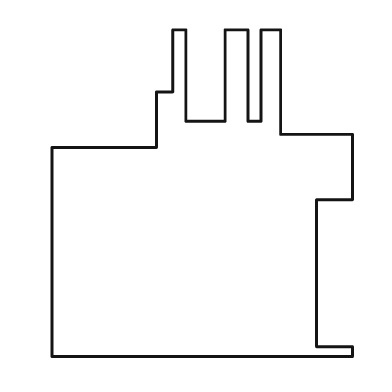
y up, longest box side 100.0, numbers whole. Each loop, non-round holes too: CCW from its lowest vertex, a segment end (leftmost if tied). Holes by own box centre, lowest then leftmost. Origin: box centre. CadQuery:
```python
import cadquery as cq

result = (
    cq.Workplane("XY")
    .moveTo(-46.0, -50.0)
    .lineTo(46.0, -50.0)
    .lineTo(46.0, -47.0)
    .lineTo(35.0, -47.0)
    .lineTo(35.0, -2.0)
    .lineTo(46.0, -2.0)
    .lineTo(46.0, 18.0)
    .lineTo(24.0, 18.0)
    .lineTo(24.0, 50.0)
    .lineTo(18.0, 50.0)
    .lineTo(18.0, 22.0)
    .lineTo(14.0, 22.0)
    .lineTo(14.0, 50.0)
    .lineTo(7.0, 50.0)
    .lineTo(7.0, 22.0)
    .lineTo(-5.0, 22.0)
    .lineTo(-5.0, 50.0)
    .lineTo(-9.0, 50.0)
    .lineTo(-9.0, 31.0)
    .lineTo(-14.0, 31.0)
    .lineTo(-14.0, 14.0)
    .lineTo(-46.0, 14.0)
    .close()
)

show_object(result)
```